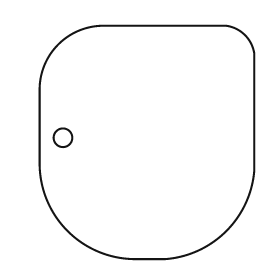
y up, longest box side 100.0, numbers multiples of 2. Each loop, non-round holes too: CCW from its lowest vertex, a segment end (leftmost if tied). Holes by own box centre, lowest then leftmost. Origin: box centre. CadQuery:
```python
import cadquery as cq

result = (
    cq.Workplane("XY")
    .moveTo(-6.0, -50.0)
    .lineTo(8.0, -50.0)
    .threePointArc((34.0, -38.0), (46.0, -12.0))
    .lineTo(46.0, 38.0)
    .threePointArc((42.0, 46.0), (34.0, 50.0))
    .lineTo(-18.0, 50.0)
    .threePointArc((-38.0, 42.0), (-46.0, 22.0))
    .lineTo(-46.0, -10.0)
    .threePointArc((-34.0, -38.0), (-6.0, -50.0))
    .close()
    .moveTo(-36.0, 2.0)
    .circle(4.0)
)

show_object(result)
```